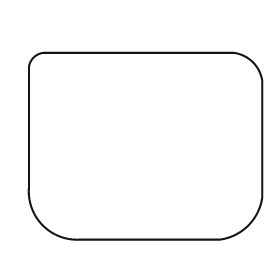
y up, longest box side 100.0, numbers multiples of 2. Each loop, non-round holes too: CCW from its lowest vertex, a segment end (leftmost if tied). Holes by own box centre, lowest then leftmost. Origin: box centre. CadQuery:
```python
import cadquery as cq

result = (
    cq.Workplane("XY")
    .moveTo(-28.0, -40.0)
    .lineTo(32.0, -40.0)
    .threePointArc((44.0, -34.0), (50.0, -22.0))
    .lineTo(50.0, 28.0)
    .threePointArc((46.0, 36.0), (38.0, 40.0))
    .lineTo(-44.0, 40.0)
    .threePointArc((-48.0, 38.0), (-50.0, 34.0))
    .lineTo(-50.0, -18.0)
    .threePointArc((-44.0, -34.0), (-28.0, -40.0))
    .close()
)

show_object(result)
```